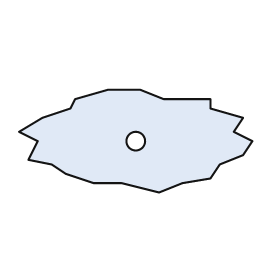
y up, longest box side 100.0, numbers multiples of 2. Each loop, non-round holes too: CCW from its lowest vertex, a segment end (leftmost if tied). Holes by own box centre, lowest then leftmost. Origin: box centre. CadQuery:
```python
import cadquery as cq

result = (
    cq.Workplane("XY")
    .moveTo(10.0, -22.0)
    .lineTo(20.0, -18.0)
    .lineTo(32.0, -16.0)
    .lineTo(36.0, -10.0)
    .lineTo(46.0, -6.0)
    .lineTo(50.0, 0.0)
    .lineTo(42.0, 4.0)
    .lineTo(46.0, 10.0)
    .lineTo(32.0, 14.0)
    .lineTo(32.0, 18.0)
    .lineTo(12.0, 18.0)
    .lineTo(2.0, 22.0)
    .lineTo(-12.0, 22.0)
    .lineTo(-26.0, 18.0)
    .lineTo(-28.0, 14.0)
    .lineTo(-40.0, 10.0)
    .lineTo(-50.0, 4.0)
    .lineTo(-42.0, 0.0)
    .lineTo(-46.0, -8.0)
    .lineTo(-36.0, -10.0)
    .lineTo(-30.0, -14.0)
    .lineTo(-18.0, -18.0)
    .lineTo(-6.0, -18.0)
    .close()
    .moveTo(0.0, 0.0)
    .circle(4.0)
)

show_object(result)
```